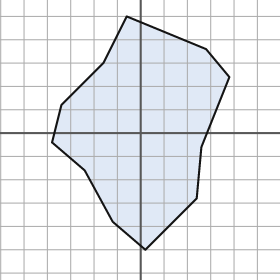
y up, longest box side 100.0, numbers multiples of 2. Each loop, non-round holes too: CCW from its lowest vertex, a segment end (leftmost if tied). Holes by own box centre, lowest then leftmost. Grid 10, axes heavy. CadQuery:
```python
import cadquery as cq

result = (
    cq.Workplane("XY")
    .moveTo(2.0, -50.0)
    .lineTo(24.0, -28.0)
    .lineTo(26.0, -6.0)
    .lineTo(38.0, 24.0)
    .lineTo(28.0, 36.0)
    .lineTo(-6.0, 50.0)
    .lineTo(-16.0, 30.0)
    .lineTo(-34.0, 12.0)
    .lineTo(-38.0, -4.0)
    .lineTo(-24.0, -16.0)
    .lineTo(-12.0, -38.0)
    .close()
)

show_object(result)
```